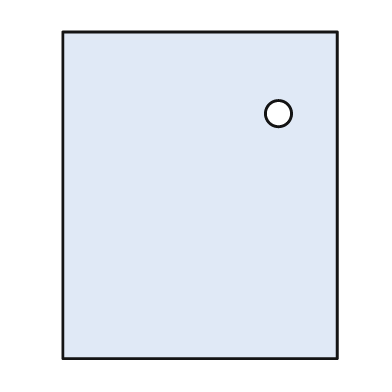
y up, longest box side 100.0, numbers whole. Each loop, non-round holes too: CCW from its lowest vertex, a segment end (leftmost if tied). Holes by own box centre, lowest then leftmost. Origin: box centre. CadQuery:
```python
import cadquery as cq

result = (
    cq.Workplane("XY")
    .moveTo(-42.0, -50.0)
    .lineTo(42.0, -50.0)
    .lineTo(42.0, 50.0)
    .lineTo(-42.0, 50.0)
    .close()
    .moveTo(24.0, 25.0)
    .circle(4.0)
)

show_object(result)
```